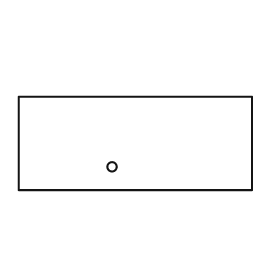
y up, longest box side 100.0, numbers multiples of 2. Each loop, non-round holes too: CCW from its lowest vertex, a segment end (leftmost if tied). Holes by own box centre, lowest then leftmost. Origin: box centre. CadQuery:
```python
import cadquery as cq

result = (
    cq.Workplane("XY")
    .moveTo(-50.0, -20.0)
    .lineTo(50.0, -20.0)
    .lineTo(50.0, 20.0)
    .lineTo(-50.0, 20.0)
    .close()
    .moveTo(-10.0, -10.0)
    .circle(2.0)
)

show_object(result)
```